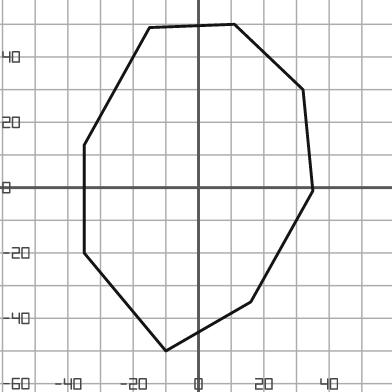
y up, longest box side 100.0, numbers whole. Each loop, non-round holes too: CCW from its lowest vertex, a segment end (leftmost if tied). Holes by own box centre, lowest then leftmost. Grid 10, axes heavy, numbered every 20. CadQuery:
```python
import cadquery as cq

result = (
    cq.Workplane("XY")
    .moveTo(-10.0, -50.0)
    .lineTo(16.0, -35.0)
    .lineTo(35.0, -1.0)
    .lineTo(32.0, 30.0)
    .lineTo(11.0, 50.0)
    .lineTo(-15.0, 49.0)
    .lineTo(-35.0, 13.0)
    .lineTo(-35.0, -20.0)
    .close()
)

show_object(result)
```